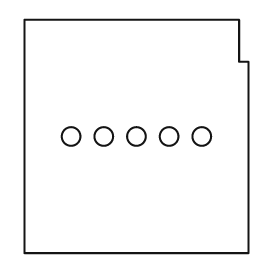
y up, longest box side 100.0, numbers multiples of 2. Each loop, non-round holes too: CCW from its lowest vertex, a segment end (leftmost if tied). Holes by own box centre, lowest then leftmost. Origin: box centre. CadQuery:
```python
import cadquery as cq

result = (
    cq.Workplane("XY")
    .moveTo(-48.0, -50.0)
    .lineTo(48.0, -50.0)
    .lineTo(48.0, 32.0)
    .lineTo(44.0, 32.0)
    .lineTo(44.0, 50.0)
    .lineTo(-48.0, 50.0)
    .close()
    .moveTo(-28.0, 0.0)
    .circle(4.0)
    .moveTo(-14.0, 0.0)
    .circle(4.0)
    .moveTo(0.0, 0.0)
    .circle(4.0)
    .moveTo(14.0, 0.0)
    .circle(4.0)
    .moveTo(28.0, 0.0)
    .circle(4.0)
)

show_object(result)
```